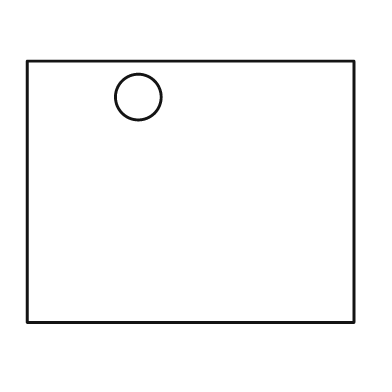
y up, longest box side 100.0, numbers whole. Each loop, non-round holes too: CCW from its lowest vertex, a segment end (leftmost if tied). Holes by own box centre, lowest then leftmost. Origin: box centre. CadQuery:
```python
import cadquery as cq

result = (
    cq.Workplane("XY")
    .moveTo(-50.0, -40.0)
    .lineTo(50.0, -40.0)
    .lineTo(50.0, 40.0)
    .lineTo(-50.0, 40.0)
    .close()
    .moveTo(-16.0, 29.0)
    .circle(7.0)
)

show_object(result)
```